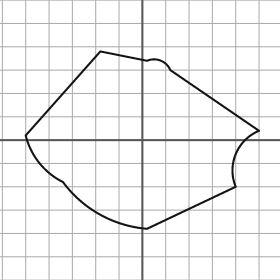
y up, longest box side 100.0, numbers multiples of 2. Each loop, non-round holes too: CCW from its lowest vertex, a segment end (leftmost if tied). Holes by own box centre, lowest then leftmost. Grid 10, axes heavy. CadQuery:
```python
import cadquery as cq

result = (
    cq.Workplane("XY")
    .moveTo(2.0, -38.0)
    .lineTo(40.0, -20.0)
    .threePointArc((40.0, -6.0), (50.0, 4.0))
    .lineTo(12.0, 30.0)
    .threePointArc((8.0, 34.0), (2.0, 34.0))
    .lineTo(-18.0, 38.0)
    .lineTo(-50.0, 2.0)
    .threePointArc((-44.0, -10.0), (-34.0, -18.0))
    .threePointArc((-18.0, -32.0), (2.0, -38.0))
    .close()
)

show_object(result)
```